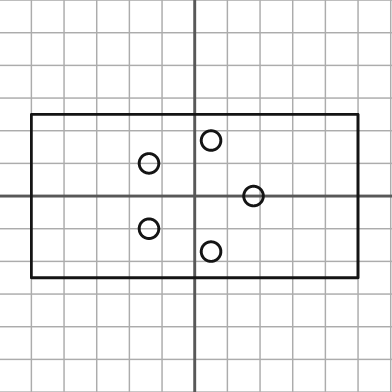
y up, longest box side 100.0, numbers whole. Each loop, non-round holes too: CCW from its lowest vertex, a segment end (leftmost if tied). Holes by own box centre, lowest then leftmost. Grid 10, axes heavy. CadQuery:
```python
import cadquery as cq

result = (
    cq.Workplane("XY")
    .moveTo(-50.0, -25.0)
    .lineTo(50.0, -25.0)
    .lineTo(50.0, 25.0)
    .lineTo(-50.0, 25.0)
    .close()
    .moveTo(5.0, -17.0)
    .circle(3.0)
    .moveTo(-14.0, -10.0)
    .circle(3.0)
    .moveTo(18.0, 0.0)
    .circle(3.0)
    .moveTo(-14.0, 10.0)
    .circle(3.0)
    .moveTo(5.0, 17.0)
    .circle(3.0)
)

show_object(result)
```